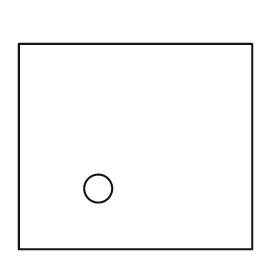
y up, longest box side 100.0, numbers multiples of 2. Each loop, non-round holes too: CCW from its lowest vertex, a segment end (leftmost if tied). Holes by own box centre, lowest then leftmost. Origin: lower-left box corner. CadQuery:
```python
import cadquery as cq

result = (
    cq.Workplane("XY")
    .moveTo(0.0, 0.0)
    .lineTo(100.0, 0.0)
    .lineTo(100.0, 88.0)
    .lineTo(0.0, 88.0)
    .close()
    .moveTo(34.0, 26.0)
    .circle(6.0)
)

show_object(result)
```